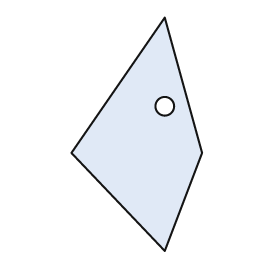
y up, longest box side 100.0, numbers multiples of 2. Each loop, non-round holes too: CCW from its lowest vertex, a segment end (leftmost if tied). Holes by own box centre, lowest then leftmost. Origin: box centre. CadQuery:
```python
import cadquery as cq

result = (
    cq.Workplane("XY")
    .moveTo(12.0, -50.0)
    .lineTo(28.0, -8.0)
    .lineTo(12.0, 50.0)
    .lineTo(-28.0, -8.0)
    .close()
    .moveTo(12.0, 12.0)
    .circle(4.0)
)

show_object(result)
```